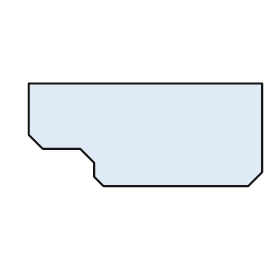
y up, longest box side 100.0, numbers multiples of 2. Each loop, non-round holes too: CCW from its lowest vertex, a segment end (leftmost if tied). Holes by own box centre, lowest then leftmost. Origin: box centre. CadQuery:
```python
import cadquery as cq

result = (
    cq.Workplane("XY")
    .moveTo(-18.0, -22.0)
    .lineTo(44.0, -22.0)
    .lineTo(50.0, -16.0)
    .lineTo(50.0, 22.0)
    .lineTo(-50.0, 22.0)
    .lineTo(-50.0, 0.0)
    .lineTo(-44.0, -6.0)
    .lineTo(-28.0, -6.0)
    .lineTo(-22.0, -12.0)
    .lineTo(-22.0, -18.0)
    .close()
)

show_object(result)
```